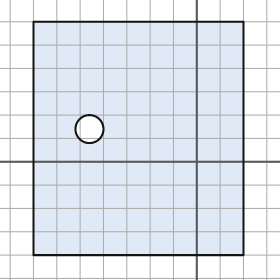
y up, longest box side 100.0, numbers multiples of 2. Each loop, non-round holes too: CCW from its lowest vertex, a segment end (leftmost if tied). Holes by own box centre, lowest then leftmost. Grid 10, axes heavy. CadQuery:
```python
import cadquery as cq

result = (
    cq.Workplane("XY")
    .moveTo(-70.0, -40.0)
    .lineTo(20.0, -40.0)
    .lineTo(20.0, 60.0)
    .lineTo(-70.0, 60.0)
    .close()
    .moveTo(-46.0, 14.0)
    .circle(6.0)
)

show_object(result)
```